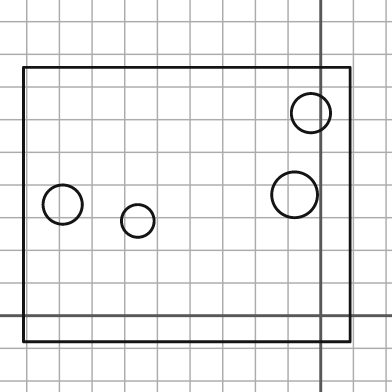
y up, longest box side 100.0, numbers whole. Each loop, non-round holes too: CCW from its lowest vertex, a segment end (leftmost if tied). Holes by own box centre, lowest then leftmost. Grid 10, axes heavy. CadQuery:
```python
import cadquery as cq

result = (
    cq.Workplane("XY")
    .moveTo(-91.0, -8.0)
    .lineTo(9.0, -8.0)
    .lineTo(9.0, 76.0)
    .lineTo(-91.0, 76.0)
    .close()
    .moveTo(-56.0, 29.0)
    .circle(5.0)
    .moveTo(-79.0, 34.0)
    .circle(6.0)
    .moveTo(-8.0, 37.0)
    .circle(7.0)
    .moveTo(-3.0, 62.0)
    .circle(6.0)
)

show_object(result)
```